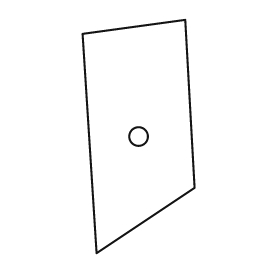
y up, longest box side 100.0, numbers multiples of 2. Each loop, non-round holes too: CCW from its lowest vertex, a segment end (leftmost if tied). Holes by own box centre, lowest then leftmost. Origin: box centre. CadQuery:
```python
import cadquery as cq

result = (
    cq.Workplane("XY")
    .moveTo(-18.0, -50.0)
    .lineTo(24.0, -22.0)
    .lineTo(20.0, 50.0)
    .lineTo(-24.0, 44.0)
    .close()
    .moveTo(0.0, 0.0)
    .circle(4.0)
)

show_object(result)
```